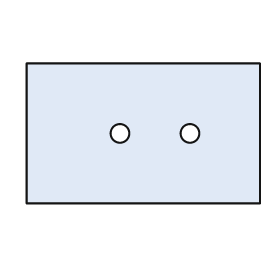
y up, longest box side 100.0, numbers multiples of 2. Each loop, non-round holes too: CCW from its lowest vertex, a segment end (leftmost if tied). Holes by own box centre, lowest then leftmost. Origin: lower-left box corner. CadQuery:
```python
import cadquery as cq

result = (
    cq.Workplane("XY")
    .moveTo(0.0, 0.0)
    .lineTo(100.0, 0.0)
    .lineTo(100.0, 60.0)
    .lineTo(0.0, 60.0)
    .close()
    .moveTo(40.0, 30.0)
    .circle(4.0)
    .moveTo(70.0, 30.0)
    .circle(4.0)
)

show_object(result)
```